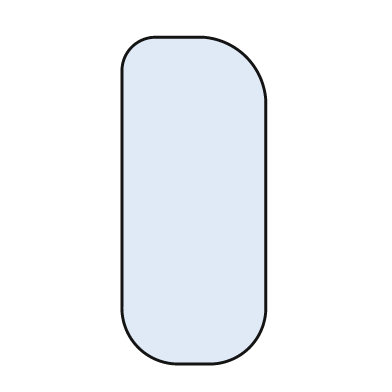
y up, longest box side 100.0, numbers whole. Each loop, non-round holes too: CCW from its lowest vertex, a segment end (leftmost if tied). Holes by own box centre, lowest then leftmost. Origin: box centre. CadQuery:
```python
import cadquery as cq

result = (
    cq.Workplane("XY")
    .moveTo(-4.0, -50.0)
    .lineTo(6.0, -50.0)
    .threePointArc((17.0, -45.0), (22.0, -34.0))
    .lineTo(22.0, 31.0)
    .threePointArc((16.0, 44.0), (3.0, 50.0))
    .lineTo(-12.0, 50.0)
    .threePointArc((-19.0, 47.0), (-22.0, 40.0))
    .lineTo(-22.0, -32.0)
    .threePointArc((-17.0, -45.0), (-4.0, -50.0))
    .close()
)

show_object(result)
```